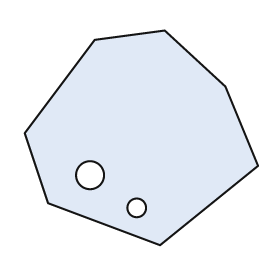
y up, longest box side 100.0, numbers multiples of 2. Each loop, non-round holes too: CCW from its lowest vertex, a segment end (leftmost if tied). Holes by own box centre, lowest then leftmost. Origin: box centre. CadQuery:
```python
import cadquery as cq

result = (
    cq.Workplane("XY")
    .moveTo(8.0, -46.0)
    .lineTo(50.0, -12.0)
    .lineTo(36.0, 22.0)
    .lineTo(10.0, 46.0)
    .lineTo(-20.0, 42.0)
    .lineTo(-50.0, 2.0)
    .lineTo(-40.0, -28.0)
    .close()
    .moveTo(-2.0, -30.0)
    .circle(4.0)
    .moveTo(-22.0, -16.0)
    .circle(6.0)
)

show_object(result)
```